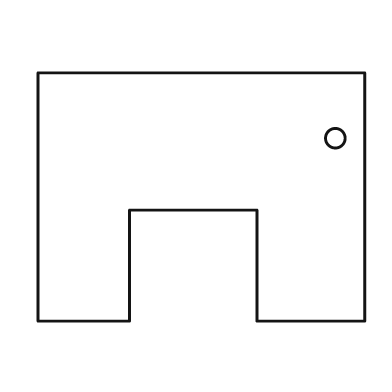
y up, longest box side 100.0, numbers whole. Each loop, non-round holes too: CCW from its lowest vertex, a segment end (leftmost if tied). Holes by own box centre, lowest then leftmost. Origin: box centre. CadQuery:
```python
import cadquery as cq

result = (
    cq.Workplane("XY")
    .moveTo(-50.0, -38.0)
    .lineTo(-22.0, -38.0)
    .lineTo(-22.0, -4.0)
    .lineTo(17.0, -4.0)
    .lineTo(17.0, -38.0)
    .lineTo(50.0, -38.0)
    .lineTo(50.0, 38.0)
    .lineTo(-50.0, 38.0)
    .close()
    .moveTo(41.0, 18.0)
    .circle(3.0)
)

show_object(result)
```